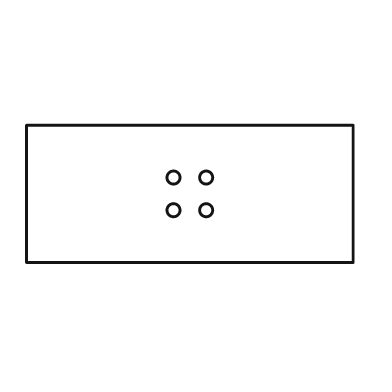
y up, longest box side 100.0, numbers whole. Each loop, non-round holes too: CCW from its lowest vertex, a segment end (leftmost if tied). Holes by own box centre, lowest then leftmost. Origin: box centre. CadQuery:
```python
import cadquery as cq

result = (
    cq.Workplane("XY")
    .moveTo(-50.0, -21.0)
    .lineTo(50.0, -21.0)
    .lineTo(50.0, 21.0)
    .lineTo(-50.0, 21.0)
    .close()
    .moveTo(-5.0, -5.0)
    .circle(2.0)
    .moveTo(5.0, -5.0)
    .circle(2.0)
    .moveTo(-5.0, 5.0)
    .circle(2.0)
    .moveTo(5.0, 5.0)
    .circle(2.0)
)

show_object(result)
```